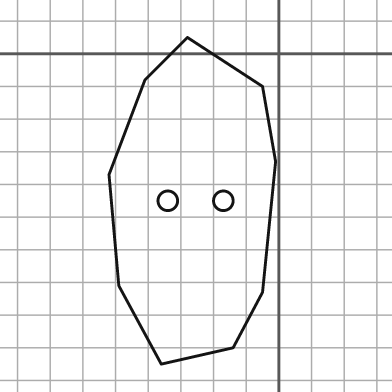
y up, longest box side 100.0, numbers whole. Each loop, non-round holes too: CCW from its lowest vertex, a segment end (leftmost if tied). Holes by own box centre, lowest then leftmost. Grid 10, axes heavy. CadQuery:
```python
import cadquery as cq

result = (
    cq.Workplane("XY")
    .moveTo(-36.0, -95.0)
    .lineTo(-14.0, -90.0)
    .lineTo(-5.0, -73.0)
    .lineTo(-1.0, -33.0)
    .lineTo(-5.0, -10.0)
    .lineTo(-28.0, 5.0)
    .lineTo(-41.0, -8.0)
    .lineTo(-52.0, -37.0)
    .lineTo(-49.0, -71.0)
    .close()
    .moveTo(-34.0, -45.0)
    .circle(3.0)
    .moveTo(-17.0, -45.0)
    .circle(3.0)
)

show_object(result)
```